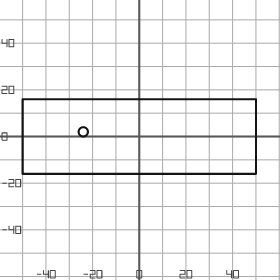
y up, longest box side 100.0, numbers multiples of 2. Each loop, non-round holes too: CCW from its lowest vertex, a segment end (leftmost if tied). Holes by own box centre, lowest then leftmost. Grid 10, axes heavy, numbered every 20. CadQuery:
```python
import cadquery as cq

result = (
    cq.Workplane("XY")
    .moveTo(-50.0, -16.0)
    .lineTo(50.0, -16.0)
    .lineTo(50.0, 16.0)
    .lineTo(-50.0, 16.0)
    .close()
    .moveTo(-24.0, 2.0)
    .circle(2.0)
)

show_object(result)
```